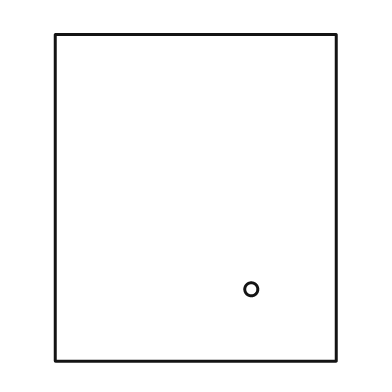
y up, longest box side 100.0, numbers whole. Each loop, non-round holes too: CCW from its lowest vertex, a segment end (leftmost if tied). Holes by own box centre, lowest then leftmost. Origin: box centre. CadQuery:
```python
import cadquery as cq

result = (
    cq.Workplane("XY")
    .moveTo(-43.0, -50.0)
    .lineTo(43.0, -50.0)
    .lineTo(43.0, 50.0)
    .lineTo(-43.0, 50.0)
    .close()
    .moveTo(17.0, -28.0)
    .circle(2.0)
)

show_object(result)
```